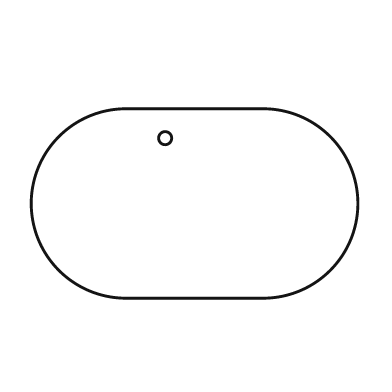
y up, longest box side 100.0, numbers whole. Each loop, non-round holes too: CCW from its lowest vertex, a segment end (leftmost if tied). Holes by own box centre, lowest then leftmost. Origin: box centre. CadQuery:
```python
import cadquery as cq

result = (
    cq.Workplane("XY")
    .moveTo(-21.0, -29.0)
    .lineTo(21.0, -29.0)
    .threePointArc((50.0, 0.0), (21.0, 29.0))
    .lineTo(-21.0, 29.0)
    .threePointArc((-50.0, 0.0), (-21.0, -29.0))
    .close()
    .moveTo(-9.0, 20.0)
    .circle(2.0)
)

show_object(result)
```